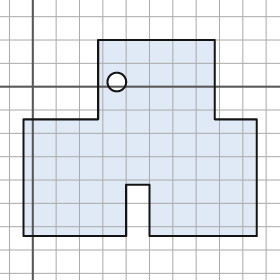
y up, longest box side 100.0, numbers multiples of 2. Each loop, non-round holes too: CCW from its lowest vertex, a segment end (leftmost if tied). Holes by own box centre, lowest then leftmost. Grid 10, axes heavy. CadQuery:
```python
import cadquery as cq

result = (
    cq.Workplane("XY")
    .moveTo(-4.0, -64.0)
    .lineTo(40.0, -64.0)
    .lineTo(40.0, -42.0)
    .lineTo(50.0, -42.0)
    .lineTo(50.0, -64.0)
    .lineTo(96.0, -64.0)
    .lineTo(96.0, -14.0)
    .lineTo(78.0, -14.0)
    .lineTo(78.0, 20.0)
    .lineTo(28.0, 20.0)
    .lineTo(28.0, -14.0)
    .lineTo(-4.0, -14.0)
    .close()
    .moveTo(36.0, 2.0)
    .circle(4.0)
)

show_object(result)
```